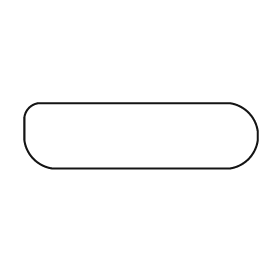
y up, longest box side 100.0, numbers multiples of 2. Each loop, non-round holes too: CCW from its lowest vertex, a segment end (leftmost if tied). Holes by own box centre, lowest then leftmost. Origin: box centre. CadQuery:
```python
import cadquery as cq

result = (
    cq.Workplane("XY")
    .moveTo(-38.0, -14.0)
    .lineTo(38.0, -14.0)
    .threePointArc((46.0, -10.0), (50.0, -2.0))
    .lineTo(50.0, 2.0)
    .threePointArc((46.0, 10.0), (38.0, 14.0))
    .lineTo(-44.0, 14.0)
    .threePointArc((-48.0, 12.0), (-50.0, 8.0))
    .lineTo(-50.0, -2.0)
    .threePointArc((-46.0, -10.0), (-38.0, -14.0))
    .close()
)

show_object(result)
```